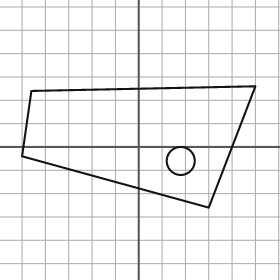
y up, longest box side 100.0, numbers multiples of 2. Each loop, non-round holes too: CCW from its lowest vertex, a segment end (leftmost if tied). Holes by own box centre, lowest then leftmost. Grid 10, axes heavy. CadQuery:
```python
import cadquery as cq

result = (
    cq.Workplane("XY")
    .moveTo(30.0, -26.0)
    .lineTo(50.0, 26.0)
    .lineTo(-46.0, 24.0)
    .lineTo(-50.0, -4.0)
    .close()
    .moveTo(18.0, -6.0)
    .circle(6.0)
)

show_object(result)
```